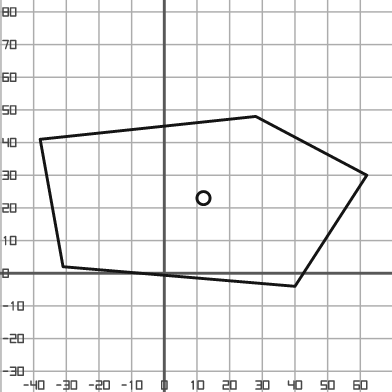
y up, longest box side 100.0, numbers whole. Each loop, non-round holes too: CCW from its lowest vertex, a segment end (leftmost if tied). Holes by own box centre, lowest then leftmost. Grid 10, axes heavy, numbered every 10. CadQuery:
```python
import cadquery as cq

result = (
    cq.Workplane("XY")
    .moveTo(40.0, -4.0)
    .lineTo(62.0, 30.0)
    .lineTo(28.0, 48.0)
    .lineTo(-38.0, 41.0)
    .lineTo(-31.0, 2.0)
    .close()
    .moveTo(12.0, 23.0)
    .circle(2.0)
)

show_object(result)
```